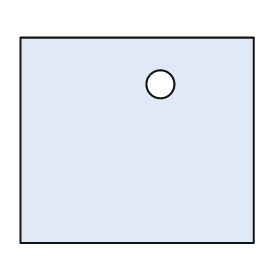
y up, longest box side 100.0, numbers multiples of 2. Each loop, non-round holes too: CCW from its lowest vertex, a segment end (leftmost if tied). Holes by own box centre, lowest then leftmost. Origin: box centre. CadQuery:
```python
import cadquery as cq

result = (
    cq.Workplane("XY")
    .moveTo(-50.0, -44.0)
    .lineTo(50.0, -44.0)
    .lineTo(50.0, 44.0)
    .lineTo(-50.0, 44.0)
    .close()
    .moveTo(10.0, 24.0)
    .circle(6.0)
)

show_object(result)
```